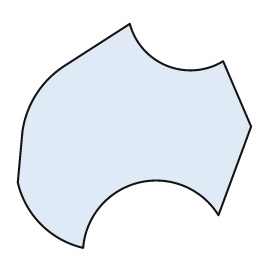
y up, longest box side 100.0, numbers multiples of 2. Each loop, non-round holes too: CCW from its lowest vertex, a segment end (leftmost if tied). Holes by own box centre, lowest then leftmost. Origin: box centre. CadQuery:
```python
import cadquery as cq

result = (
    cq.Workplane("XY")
    .moveTo(-22.0, -48.0)
    .threePointArc((2.0, -20.0), (36.0, -34.0))
    .lineTo(50.0, 4.0)
    .lineTo(38.0, 32.0)
    .threePointArc((14.0, 30.0), (-2.0, 48.0))
    .lineTo(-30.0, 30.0)
    .threePointArc((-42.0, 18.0), (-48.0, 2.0))
    .lineTo(-50.0, -20.0)
    .threePointArc((-40.0, -38.0), (-22.0, -48.0))
    .close()
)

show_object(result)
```